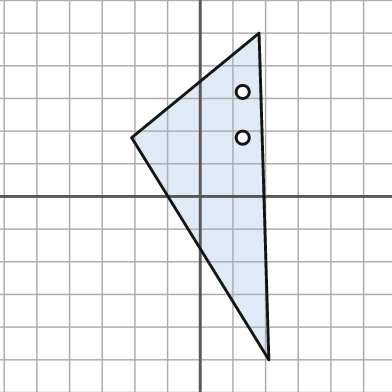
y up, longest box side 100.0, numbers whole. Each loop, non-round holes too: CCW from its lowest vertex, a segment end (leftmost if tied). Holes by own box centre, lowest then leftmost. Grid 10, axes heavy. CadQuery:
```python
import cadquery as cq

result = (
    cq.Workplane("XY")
    .moveTo(21.0, -50.0)
    .lineTo(18.0, 50.0)
    .lineTo(-21.0, 18.0)
    .close()
    .moveTo(13.0, 18.0)
    .circle(2.0)
    .moveTo(13.0, 32.0)
    .circle(2.0)
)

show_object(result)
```